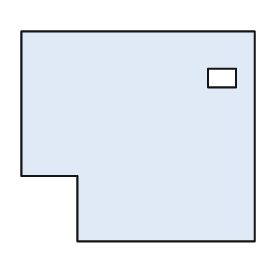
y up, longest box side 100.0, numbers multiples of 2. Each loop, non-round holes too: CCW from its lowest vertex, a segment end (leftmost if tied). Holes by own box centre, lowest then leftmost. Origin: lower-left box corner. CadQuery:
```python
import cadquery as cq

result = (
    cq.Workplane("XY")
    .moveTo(24.0, 0.0)
    .lineTo(100.0, 0.0)
    .lineTo(100.0, 90.0)
    .lineTo(0.0, 90.0)
    .lineTo(0.0, 28.0)
    .lineTo(24.0, 28.0)
    .close()
    .moveTo(80.0, 66.0)
    .lineTo(92.0, 66.0)
    .lineTo(92.0, 74.0)
    .lineTo(80.0, 74.0)
    .close()
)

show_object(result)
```